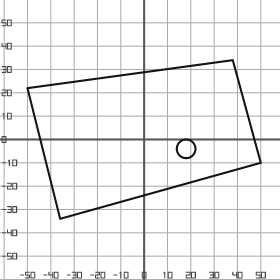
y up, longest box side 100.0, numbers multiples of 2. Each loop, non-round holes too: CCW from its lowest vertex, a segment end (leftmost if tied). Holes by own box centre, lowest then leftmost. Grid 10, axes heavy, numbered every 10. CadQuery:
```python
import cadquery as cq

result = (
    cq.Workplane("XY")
    .moveTo(-36.0, -34.0)
    .lineTo(50.0, -10.0)
    .lineTo(38.0, 34.0)
    .lineTo(-50.0, 22.0)
    .close()
    .moveTo(18.0, -4.0)
    .circle(4.0)
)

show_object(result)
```